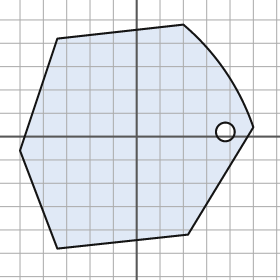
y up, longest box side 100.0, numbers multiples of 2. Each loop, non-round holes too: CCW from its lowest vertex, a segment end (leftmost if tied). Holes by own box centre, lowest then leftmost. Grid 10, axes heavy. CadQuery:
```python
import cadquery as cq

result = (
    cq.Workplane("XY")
    .moveTo(-34.0, -48.0)
    .lineTo(22.0, -42.0)
    .lineTo(50.0, 4.0)
    .threePointArc((38.0, 28.0), (20.0, 48.0))
    .lineTo(-34.0, 42.0)
    .lineTo(-50.0, -6.0)
    .close()
    .moveTo(38.0, 2.0)
    .circle(4.0)
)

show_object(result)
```